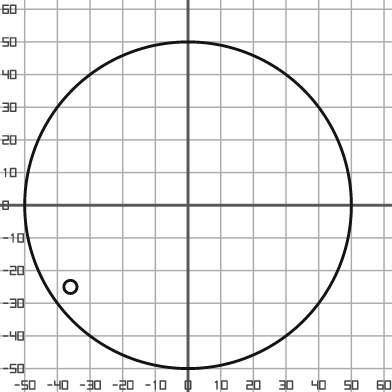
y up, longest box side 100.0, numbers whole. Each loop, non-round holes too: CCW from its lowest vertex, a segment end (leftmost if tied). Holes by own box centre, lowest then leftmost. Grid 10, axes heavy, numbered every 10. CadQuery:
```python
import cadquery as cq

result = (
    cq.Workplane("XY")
    .moveTo(0.0, 0.0)
    .circle(50.0)
    .moveTo(-36.0, -25.0)
    .circle(2.0)
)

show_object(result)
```